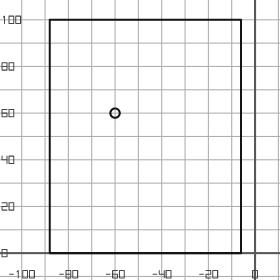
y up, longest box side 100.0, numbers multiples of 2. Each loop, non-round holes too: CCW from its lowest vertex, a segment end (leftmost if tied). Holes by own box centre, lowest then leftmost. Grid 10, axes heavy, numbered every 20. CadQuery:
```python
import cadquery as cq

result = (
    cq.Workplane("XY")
    .moveTo(-88.0, 0.0)
    .lineTo(-6.0, 0.0)
    .lineTo(-6.0, 100.0)
    .lineTo(-88.0, 100.0)
    .close()
    .moveTo(-60.0, 60.0)
    .circle(2.0)
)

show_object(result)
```